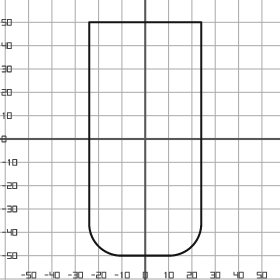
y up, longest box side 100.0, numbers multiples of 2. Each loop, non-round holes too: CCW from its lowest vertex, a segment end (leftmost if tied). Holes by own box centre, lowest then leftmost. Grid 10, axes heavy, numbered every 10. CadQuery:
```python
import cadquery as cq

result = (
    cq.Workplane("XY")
    .moveTo(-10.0, -50.0)
    .lineTo(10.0, -50.0)
    .threePointArc((20.0, -46.0), (24.0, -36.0))
    .lineTo(24.0, 50.0)
    .lineTo(-24.0, 50.0)
    .lineTo(-24.0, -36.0)
    .threePointArc((-20.0, -46.0), (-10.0, -50.0))
    .close()
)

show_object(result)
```